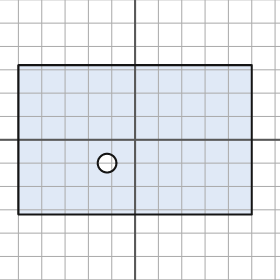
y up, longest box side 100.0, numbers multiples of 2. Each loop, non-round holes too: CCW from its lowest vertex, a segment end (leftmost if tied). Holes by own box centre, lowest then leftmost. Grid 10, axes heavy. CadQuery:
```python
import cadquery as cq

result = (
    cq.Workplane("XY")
    .moveTo(-50.0, -32.0)
    .lineTo(50.0, -32.0)
    .lineTo(50.0, 32.0)
    .lineTo(-50.0, 32.0)
    .close()
    .moveTo(-12.0, -10.0)
    .circle(4.0)
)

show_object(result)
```